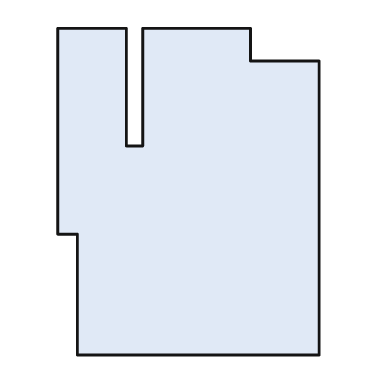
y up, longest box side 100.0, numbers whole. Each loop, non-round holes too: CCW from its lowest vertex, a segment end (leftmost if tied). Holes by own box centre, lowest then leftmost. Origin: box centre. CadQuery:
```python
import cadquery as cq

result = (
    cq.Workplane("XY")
    .moveTo(-34.0, -50.0)
    .lineTo(40.0, -50.0)
    .lineTo(40.0, 40.0)
    .lineTo(19.0, 40.0)
    .lineTo(19.0, 50.0)
    .lineTo(-14.0, 50.0)
    .lineTo(-14.0, 14.0)
    .lineTo(-19.0, 14.0)
    .lineTo(-19.0, 50.0)
    .lineTo(-40.0, 50.0)
    .lineTo(-40.0, -13.0)
    .lineTo(-34.0, -13.0)
    .close()
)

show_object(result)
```